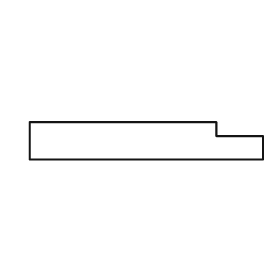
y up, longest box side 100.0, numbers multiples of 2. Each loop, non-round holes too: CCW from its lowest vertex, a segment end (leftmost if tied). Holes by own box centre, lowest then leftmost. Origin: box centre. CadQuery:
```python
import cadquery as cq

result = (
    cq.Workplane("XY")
    .moveTo(-50.0, -8.0)
    .lineTo(50.0, -8.0)
    .lineTo(50.0, 2.0)
    .lineTo(30.0, 2.0)
    .lineTo(30.0, 8.0)
    .lineTo(-50.0, 8.0)
    .close()
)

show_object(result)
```